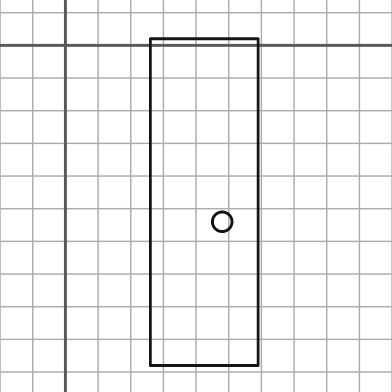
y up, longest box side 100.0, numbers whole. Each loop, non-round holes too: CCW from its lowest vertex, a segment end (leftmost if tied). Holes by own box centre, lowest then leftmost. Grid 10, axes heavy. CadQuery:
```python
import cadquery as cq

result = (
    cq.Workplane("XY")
    .moveTo(26.0, -98.0)
    .lineTo(59.0, -98.0)
    .lineTo(59.0, 2.0)
    .lineTo(26.0, 2.0)
    .close()
    .moveTo(48.0, -54.0)
    .circle(3.0)
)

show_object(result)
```